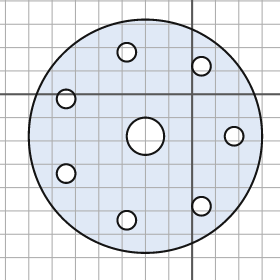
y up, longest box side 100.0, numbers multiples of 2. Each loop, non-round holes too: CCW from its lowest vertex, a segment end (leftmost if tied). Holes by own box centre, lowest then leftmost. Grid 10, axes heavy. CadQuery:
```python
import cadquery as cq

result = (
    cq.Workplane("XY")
    .moveTo(-20.0, -18.0)
    .circle(50.0)
    .moveTo(-28.0, -54.0)
    .circle(4.0)
    .moveTo(4.0, -48.0)
    .circle(4.0)
    .moveTo(-54.0, -34.0)
    .circle(4.0)
    .moveTo(-20.0, -18.0)
    .circle(8.0)
    .moveTo(18.0, -18.0)
    .circle(4.0)
    .moveTo(-54.0, -2.0)
    .circle(4.0)
    .moveTo(4.0, 12.0)
    .circle(4.0)
    .moveTo(-28.0, 18.0)
    .circle(4.0)
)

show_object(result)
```